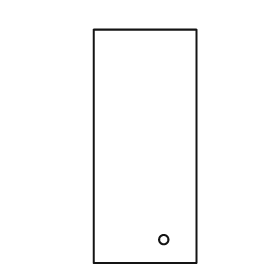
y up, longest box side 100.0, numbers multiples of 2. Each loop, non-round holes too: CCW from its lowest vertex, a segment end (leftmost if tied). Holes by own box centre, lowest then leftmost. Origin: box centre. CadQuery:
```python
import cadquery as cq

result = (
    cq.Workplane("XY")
    .moveTo(-22.0, -50.0)
    .lineTo(22.0, -50.0)
    .lineTo(22.0, 50.0)
    .lineTo(-22.0, 50.0)
    .close()
    .moveTo(8.0, -40.0)
    .circle(2.0)
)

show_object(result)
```